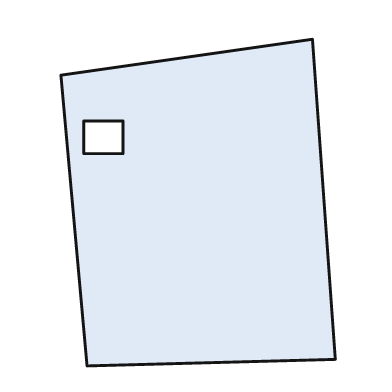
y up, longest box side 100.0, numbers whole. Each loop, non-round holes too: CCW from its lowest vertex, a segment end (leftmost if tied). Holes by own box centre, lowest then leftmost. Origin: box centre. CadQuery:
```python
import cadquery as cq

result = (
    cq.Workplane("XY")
    .moveTo(-34.0, -50.0)
    .lineTo(42.0, -48.0)
    .lineTo(35.0, 50.0)
    .lineTo(-42.0, 39.0)
    .close()
    .moveTo(-35.0, 15.0)
    .lineTo(-23.0, 15.0)
    .lineTo(-23.0, 25.0)
    .lineTo(-35.0, 25.0)
    .close()
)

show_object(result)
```